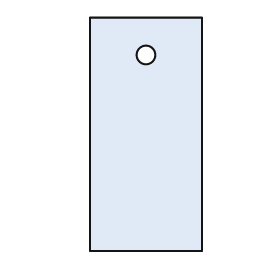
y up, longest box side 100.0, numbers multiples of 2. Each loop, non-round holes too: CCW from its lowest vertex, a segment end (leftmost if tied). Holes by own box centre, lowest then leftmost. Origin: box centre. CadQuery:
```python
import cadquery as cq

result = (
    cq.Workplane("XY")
    .moveTo(-24.0, -50.0)
    .lineTo(24.0, -50.0)
    .lineTo(24.0, 50.0)
    .lineTo(-24.0, 50.0)
    .close()
    .moveTo(0.0, 34.0)
    .circle(4.0)
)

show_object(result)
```